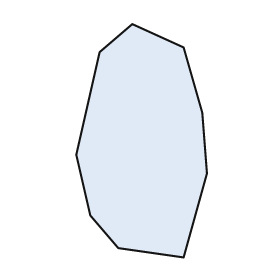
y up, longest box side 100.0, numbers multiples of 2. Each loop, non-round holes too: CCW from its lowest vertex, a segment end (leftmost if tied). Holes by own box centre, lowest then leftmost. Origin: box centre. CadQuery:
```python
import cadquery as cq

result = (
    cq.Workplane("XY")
    .moveTo(18.0, -50.0)
    .lineTo(28.0, -14.0)
    .lineTo(26.0, 12.0)
    .lineTo(18.0, 40.0)
    .lineTo(-4.0, 50.0)
    .lineTo(-18.0, 38.0)
    .lineTo(-28.0, -6.0)
    .lineTo(-22.0, -32.0)
    .lineTo(-10.0, -46.0)
    .close()
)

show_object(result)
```